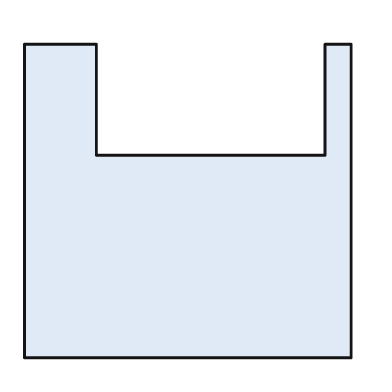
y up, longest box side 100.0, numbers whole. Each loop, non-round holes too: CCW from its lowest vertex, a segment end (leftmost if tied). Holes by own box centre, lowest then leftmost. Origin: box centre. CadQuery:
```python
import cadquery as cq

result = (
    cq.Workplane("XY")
    .moveTo(-50.0, -48.0)
    .lineTo(50.0, -48.0)
    .lineTo(50.0, 48.0)
    .lineTo(42.0, 48.0)
    .lineTo(42.0, 14.0)
    .lineTo(-28.0, 14.0)
    .lineTo(-28.0, 48.0)
    .lineTo(-50.0, 48.0)
    .close()
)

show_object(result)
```